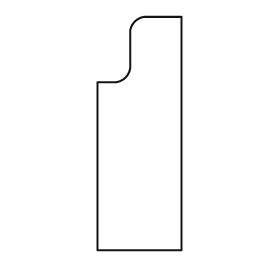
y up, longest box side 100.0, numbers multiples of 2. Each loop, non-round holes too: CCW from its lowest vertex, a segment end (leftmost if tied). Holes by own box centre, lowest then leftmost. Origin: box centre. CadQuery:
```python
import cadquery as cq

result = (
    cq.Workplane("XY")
    .moveTo(-18.0, -50.0)
    .lineTo(18.0, -50.0)
    .lineTo(18.0, 50.0)
    .lineTo(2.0, 50.0)
    .threePointArc((-2.0, 48.0), (-4.0, 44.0))
    .lineTo(-4.0, 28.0)
    .threePointArc((-6.0, 24.0), (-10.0, 22.0))
    .lineTo(-18.0, 22.0)
    .close()
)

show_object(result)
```